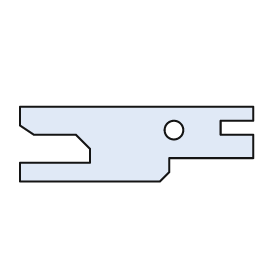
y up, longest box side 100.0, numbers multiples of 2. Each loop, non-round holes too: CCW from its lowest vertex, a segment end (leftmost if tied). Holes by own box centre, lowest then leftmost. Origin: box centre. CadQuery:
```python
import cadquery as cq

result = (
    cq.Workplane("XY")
    .moveTo(-50.0, -16.0)
    .lineTo(10.0, -16.0)
    .lineTo(14.0, -12.0)
    .lineTo(14.0, -6.0)
    .lineTo(50.0, -6.0)
    .lineTo(50.0, 4.0)
    .lineTo(36.0, 4.0)
    .lineTo(36.0, 10.0)
    .lineTo(50.0, 10.0)
    .lineTo(50.0, 16.0)
    .lineTo(-50.0, 16.0)
    .lineTo(-50.0, 8.0)
    .lineTo(-44.0, 4.0)
    .lineTo(-26.0, 4.0)
    .lineTo(-20.0, -2.0)
    .lineTo(-20.0, -8.0)
    .lineTo(-50.0, -8.0)
    .close()
    .moveTo(16.0, 6.0)
    .circle(4.0)
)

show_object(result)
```